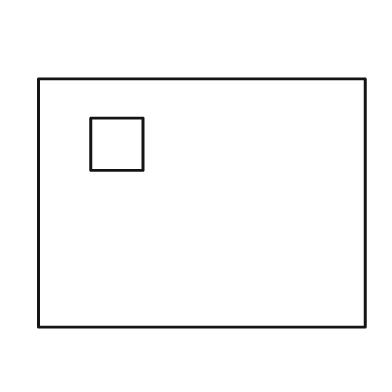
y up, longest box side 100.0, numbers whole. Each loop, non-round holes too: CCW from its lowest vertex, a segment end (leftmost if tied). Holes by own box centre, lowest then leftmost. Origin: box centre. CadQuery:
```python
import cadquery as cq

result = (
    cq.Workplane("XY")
    .moveTo(-50.0, -38.0)
    .lineTo(50.0, -38.0)
    .lineTo(50.0, 38.0)
    .lineTo(-50.0, 38.0)
    .close()
    .moveTo(-34.0, 10.0)
    .lineTo(-18.0, 10.0)
    .lineTo(-18.0, 26.0)
    .lineTo(-34.0, 26.0)
    .close()
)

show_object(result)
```